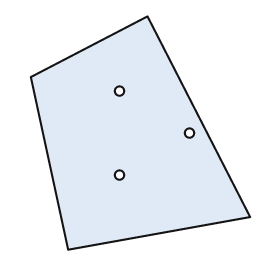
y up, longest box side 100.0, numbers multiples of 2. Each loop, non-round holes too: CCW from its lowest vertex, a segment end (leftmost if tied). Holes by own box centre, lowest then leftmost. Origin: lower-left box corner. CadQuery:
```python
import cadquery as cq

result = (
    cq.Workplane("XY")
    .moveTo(16.0, 0.0)
    .lineTo(94.0, 14.0)
    .lineTo(50.0, 100.0)
    .lineTo(0.0, 74.0)
    .close()
    .moveTo(38.0, 32.0)
    .circle(2.0)
    .moveTo(68.0, 50.0)
    .circle(2.0)
    .moveTo(38.0, 68.0)
    .circle(2.0)
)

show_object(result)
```